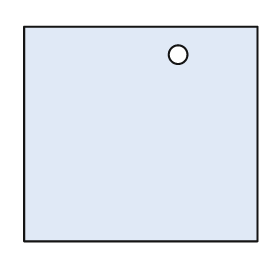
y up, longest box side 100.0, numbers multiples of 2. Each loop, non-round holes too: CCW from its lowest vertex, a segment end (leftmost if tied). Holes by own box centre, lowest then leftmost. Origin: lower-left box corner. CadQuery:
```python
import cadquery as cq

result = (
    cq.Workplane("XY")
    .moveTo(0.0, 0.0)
    .lineTo(100.0, 0.0)
    .lineTo(100.0, 92.0)
    .lineTo(0.0, 92.0)
    .close()
    .moveTo(66.0, 80.0)
    .circle(4.0)
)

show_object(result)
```